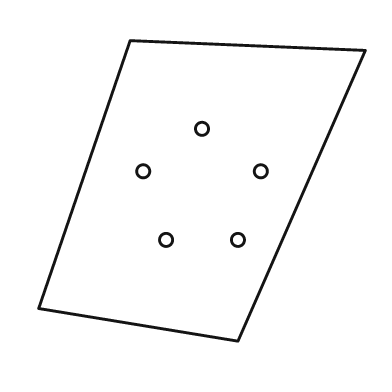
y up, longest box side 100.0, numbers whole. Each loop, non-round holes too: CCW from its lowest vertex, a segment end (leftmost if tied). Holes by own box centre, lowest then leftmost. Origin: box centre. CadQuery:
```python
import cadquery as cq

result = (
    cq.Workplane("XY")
    .moveTo(11.0, -46.0)
    .lineTo(50.0, 43.0)
    .lineTo(-22.0, 46.0)
    .lineTo(-50.0, -36.0)
    .close()
    .moveTo(-11.0, -15.0)
    .circle(2.0)
    .moveTo(11.0, -15.0)
    .circle(2.0)
    .moveTo(-18.0, 6.0)
    .circle(2.0)
    .moveTo(18.0, 6.0)
    .circle(2.0)
    .moveTo(0.0, 19.0)
    .circle(2.0)
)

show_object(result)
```